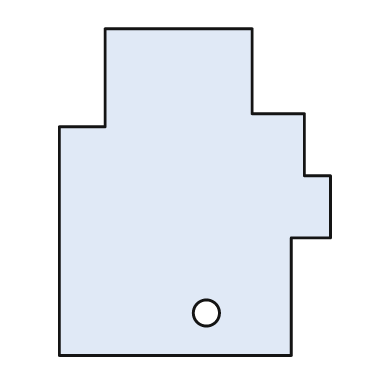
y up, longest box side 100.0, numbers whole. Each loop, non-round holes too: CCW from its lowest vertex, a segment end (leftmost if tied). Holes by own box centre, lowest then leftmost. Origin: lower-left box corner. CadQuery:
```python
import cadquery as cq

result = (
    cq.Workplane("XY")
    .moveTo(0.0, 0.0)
    .lineTo(71.0, 0.0)
    .lineTo(71.0, 36.0)
    .lineTo(83.0, 36.0)
    .lineTo(83.0, 55.0)
    .lineTo(75.0, 55.0)
    .lineTo(75.0, 74.0)
    .lineTo(59.0, 74.0)
    .lineTo(59.0, 100.0)
    .lineTo(14.0, 100.0)
    .lineTo(14.0, 70.0)
    .lineTo(0.0, 70.0)
    .close()
    .moveTo(45.0, 13.0)
    .circle(4.0)
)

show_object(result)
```